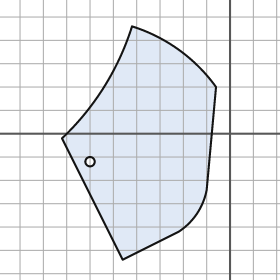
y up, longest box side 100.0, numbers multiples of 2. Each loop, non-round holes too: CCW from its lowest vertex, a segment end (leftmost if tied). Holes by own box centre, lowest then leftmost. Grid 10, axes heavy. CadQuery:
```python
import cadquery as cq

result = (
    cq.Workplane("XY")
    .moveTo(-46.0, -54.0)
    .lineTo(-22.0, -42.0)
    .threePointArc((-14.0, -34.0), (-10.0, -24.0))
    .lineTo(-6.0, 20.0)
    .threePointArc((-22.0, 36.0), (-42.0, 46.0))
    .threePointArc((-54.0, 20.0), (-72.0, -2.0))
    .close()
    .moveTo(-60.0, -12.0)
    .circle(2.0)
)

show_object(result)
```